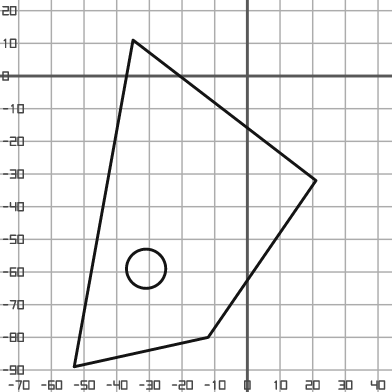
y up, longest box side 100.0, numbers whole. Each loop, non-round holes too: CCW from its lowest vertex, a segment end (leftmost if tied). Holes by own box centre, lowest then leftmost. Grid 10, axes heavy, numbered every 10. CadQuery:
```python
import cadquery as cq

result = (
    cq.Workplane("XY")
    .moveTo(-53.0, -89.0)
    .lineTo(-12.0, -80.0)
    .lineTo(21.0, -32.0)
    .lineTo(-35.0, 11.0)
    .close()
    .moveTo(-31.0, -59.0)
    .circle(6.0)
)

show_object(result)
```